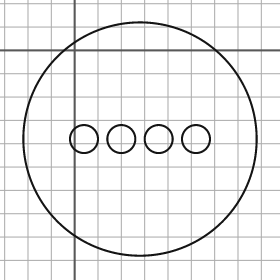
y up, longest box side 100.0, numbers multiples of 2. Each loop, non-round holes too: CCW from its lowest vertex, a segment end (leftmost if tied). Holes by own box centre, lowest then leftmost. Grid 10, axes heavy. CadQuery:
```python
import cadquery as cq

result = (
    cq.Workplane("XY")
    .moveTo(28.0, -38.0)
    .circle(50.0)
    .moveTo(4.0, -38.0)
    .circle(6.0)
    .moveTo(20.0, -38.0)
    .circle(6.0)
    .moveTo(36.0, -38.0)
    .circle(6.0)
    .moveTo(52.0, -38.0)
    .circle(6.0)
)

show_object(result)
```